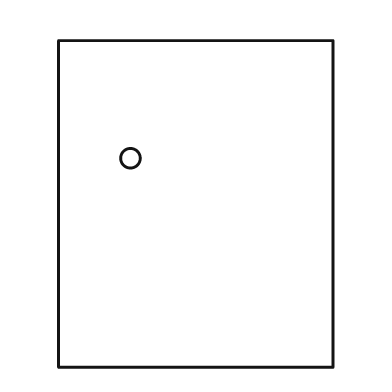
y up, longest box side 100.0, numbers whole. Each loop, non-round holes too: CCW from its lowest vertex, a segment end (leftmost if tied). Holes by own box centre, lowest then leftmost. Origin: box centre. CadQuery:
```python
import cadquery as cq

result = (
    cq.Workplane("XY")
    .moveTo(-42.0, -50.0)
    .lineTo(42.0, -50.0)
    .lineTo(42.0, 50.0)
    .lineTo(-42.0, 50.0)
    .close()
    .moveTo(-20.0, 14.0)
    .circle(3.0)
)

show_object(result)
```